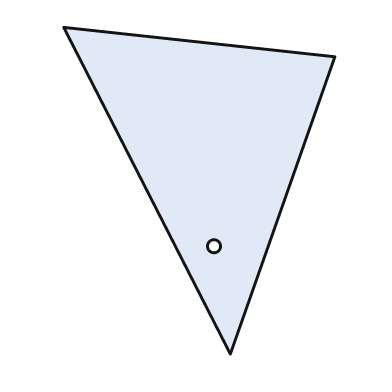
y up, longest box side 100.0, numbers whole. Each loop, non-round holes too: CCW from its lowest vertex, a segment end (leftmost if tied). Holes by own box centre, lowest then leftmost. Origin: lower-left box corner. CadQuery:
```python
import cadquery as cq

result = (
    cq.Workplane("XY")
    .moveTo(51.0, 0.0)
    .lineTo(83.0, 91.0)
    .lineTo(0.0, 100.0)
    .close()
    .moveTo(46.0, 33.0)
    .circle(2.0)
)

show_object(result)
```